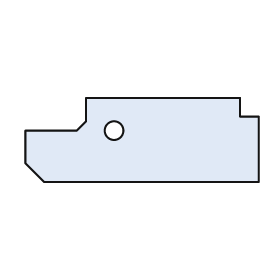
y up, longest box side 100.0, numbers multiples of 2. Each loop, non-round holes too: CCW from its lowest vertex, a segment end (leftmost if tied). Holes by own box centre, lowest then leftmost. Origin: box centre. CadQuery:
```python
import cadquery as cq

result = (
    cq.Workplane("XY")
    .moveTo(-42.0, -18.0)
    .lineTo(50.0, -18.0)
    .lineTo(50.0, 10.0)
    .lineTo(42.0, 10.0)
    .lineTo(42.0, 18.0)
    .lineTo(-24.0, 18.0)
    .lineTo(-24.0, 8.0)
    .lineTo(-28.0, 4.0)
    .lineTo(-50.0, 4.0)
    .lineTo(-50.0, -10.0)
    .close()
    .moveTo(-12.0, 4.0)
    .circle(4.0)
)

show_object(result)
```